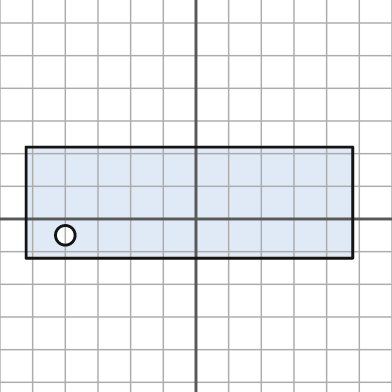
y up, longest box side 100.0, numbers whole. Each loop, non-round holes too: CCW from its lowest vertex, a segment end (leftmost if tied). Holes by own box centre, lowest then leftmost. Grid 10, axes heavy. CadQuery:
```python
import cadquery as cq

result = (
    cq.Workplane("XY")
    .moveTo(-52.0, -12.0)
    .lineTo(48.0, -12.0)
    .lineTo(48.0, 22.0)
    .lineTo(-52.0, 22.0)
    .close()
    .moveTo(-40.0, -5.0)
    .circle(3.0)
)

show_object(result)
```